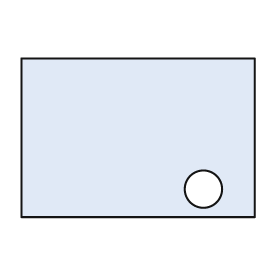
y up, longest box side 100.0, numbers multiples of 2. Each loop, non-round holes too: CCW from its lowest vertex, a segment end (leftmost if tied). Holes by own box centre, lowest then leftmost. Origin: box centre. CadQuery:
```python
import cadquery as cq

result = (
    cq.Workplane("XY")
    .moveTo(-50.0, -34.0)
    .lineTo(50.0, -34.0)
    .lineTo(50.0, 34.0)
    .lineTo(-50.0, 34.0)
    .close()
    .moveTo(28.0, -22.0)
    .circle(8.0)
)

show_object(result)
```